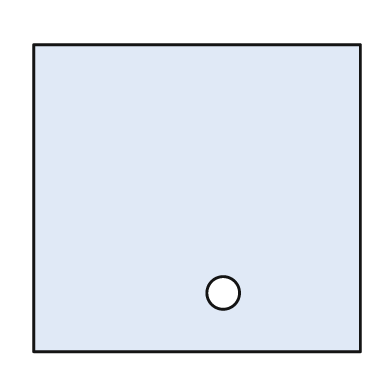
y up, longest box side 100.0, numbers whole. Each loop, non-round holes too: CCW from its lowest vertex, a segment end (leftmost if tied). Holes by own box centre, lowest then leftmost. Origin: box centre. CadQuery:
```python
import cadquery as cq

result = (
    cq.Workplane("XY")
    .moveTo(-50.0, -47.0)
    .lineTo(50.0, -47.0)
    .lineTo(50.0, 47.0)
    .lineTo(-50.0, 47.0)
    .close()
    .moveTo(8.0, -29.0)
    .circle(5.0)
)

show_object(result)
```